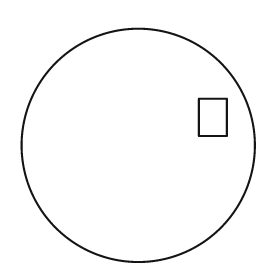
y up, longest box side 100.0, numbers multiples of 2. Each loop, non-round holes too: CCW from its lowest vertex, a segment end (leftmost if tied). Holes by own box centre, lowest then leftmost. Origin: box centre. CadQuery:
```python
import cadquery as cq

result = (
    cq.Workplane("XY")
    .moveTo(0.0, 0.0)
    .circle(50.0)
    .moveTo(26.0, 4.0)
    .lineTo(38.0, 4.0)
    .lineTo(38.0, 20.0)
    .lineTo(26.0, 20.0)
    .close()
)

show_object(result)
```